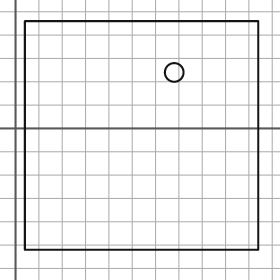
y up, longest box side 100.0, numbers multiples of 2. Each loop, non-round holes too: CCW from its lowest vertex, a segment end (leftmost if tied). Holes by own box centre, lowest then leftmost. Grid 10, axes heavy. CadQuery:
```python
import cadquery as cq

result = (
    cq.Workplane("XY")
    .moveTo(4.0, -52.0)
    .lineTo(104.0, -52.0)
    .lineTo(104.0, 46.0)
    .lineTo(4.0, 46.0)
    .close()
    .moveTo(68.0, 24.0)
    .circle(4.0)
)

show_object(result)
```